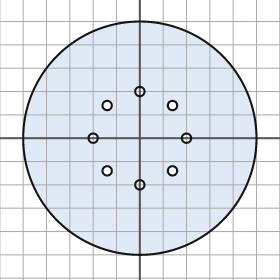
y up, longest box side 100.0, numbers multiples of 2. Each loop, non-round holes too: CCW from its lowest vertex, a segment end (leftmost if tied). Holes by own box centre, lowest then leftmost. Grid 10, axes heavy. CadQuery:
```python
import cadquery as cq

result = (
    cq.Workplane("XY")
    .moveTo(0.0, 0.0)
    .circle(50.0)
    .moveTo(0.0, -20.0)
    .circle(2.0)
    .moveTo(-14.0, -14.0)
    .circle(2.0)
    .moveTo(14.0, -14.0)
    .circle(2.0)
    .moveTo(-20.0, 0.0)
    .circle(2.0)
    .moveTo(20.0, 0.0)
    .circle(2.0)
    .moveTo(-14.0, 14.0)
    .circle(2.0)
    .moveTo(14.0, 14.0)
    .circle(2.0)
    .moveTo(0.0, 20.0)
    .circle(2.0)
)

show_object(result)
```